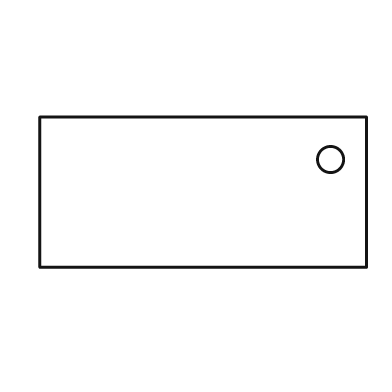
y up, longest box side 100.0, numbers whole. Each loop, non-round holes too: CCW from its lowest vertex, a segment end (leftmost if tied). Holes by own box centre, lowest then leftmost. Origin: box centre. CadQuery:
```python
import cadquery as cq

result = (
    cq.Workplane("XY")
    .moveTo(-50.0, -23.0)
    .lineTo(50.0, -23.0)
    .lineTo(50.0, 23.0)
    .lineTo(-50.0, 23.0)
    .close()
    .moveTo(39.0, 10.0)
    .circle(4.0)
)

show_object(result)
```